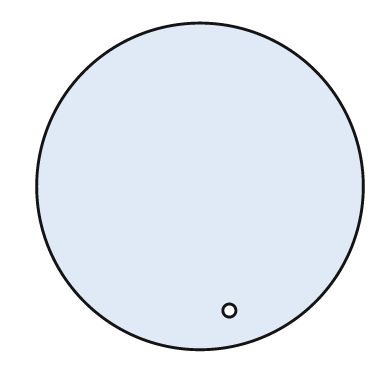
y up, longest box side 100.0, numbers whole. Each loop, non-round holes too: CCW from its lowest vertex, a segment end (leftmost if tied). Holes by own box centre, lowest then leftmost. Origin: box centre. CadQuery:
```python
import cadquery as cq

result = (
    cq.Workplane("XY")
    .moveTo(0.0, 0.0)
    .circle(50.0)
    .moveTo(9.0, -38.0)
    .circle(2.0)
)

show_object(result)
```